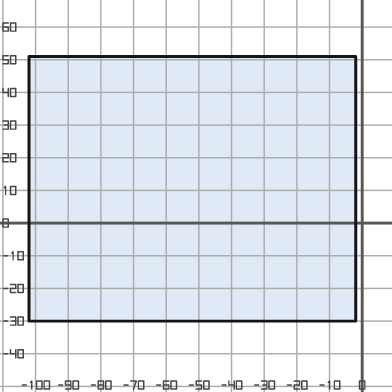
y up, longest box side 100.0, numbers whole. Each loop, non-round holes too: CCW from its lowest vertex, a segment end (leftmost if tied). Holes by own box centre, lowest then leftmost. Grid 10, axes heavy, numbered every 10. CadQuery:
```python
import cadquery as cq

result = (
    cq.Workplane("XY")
    .moveTo(-102.0, -30.0)
    .lineTo(-2.0, -30.0)
    .lineTo(-2.0, 51.0)
    .lineTo(-102.0, 51.0)
    .close()
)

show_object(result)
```